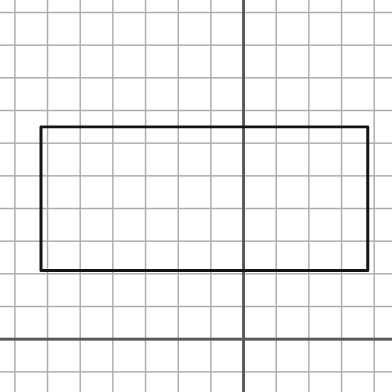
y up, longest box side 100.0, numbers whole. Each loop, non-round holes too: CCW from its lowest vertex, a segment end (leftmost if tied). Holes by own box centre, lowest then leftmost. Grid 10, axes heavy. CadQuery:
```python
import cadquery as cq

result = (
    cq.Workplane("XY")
    .moveTo(-62.0, 21.0)
    .lineTo(38.0, 21.0)
    .lineTo(38.0, 65.0)
    .lineTo(-62.0, 65.0)
    .close()
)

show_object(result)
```